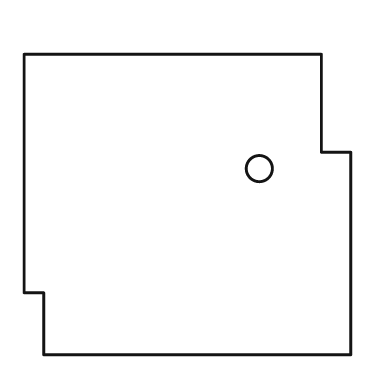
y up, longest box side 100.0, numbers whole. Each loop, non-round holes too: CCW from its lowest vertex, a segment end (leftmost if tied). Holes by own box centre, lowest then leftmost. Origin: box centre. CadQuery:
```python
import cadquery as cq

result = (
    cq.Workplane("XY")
    .moveTo(-44.0, -46.0)
    .lineTo(50.0, -46.0)
    .lineTo(50.0, 16.0)
    .lineTo(41.0, 16.0)
    .lineTo(41.0, 46.0)
    .lineTo(-50.0, 46.0)
    .lineTo(-50.0, -27.0)
    .lineTo(-44.0, -27.0)
    .close()
    .moveTo(22.0, 11.0)
    .circle(4.0)
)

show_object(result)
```